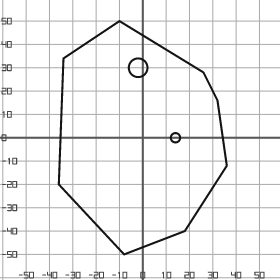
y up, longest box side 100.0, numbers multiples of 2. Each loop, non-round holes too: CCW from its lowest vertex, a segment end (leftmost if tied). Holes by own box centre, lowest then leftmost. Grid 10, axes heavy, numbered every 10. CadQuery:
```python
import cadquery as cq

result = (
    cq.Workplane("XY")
    .moveTo(-8.0, -50.0)
    .lineTo(18.0, -40.0)
    .lineTo(36.0, -12.0)
    .lineTo(32.0, 16.0)
    .lineTo(26.0, 28.0)
    .lineTo(-10.0, 50.0)
    .lineTo(-34.0, 34.0)
    .lineTo(-36.0, -20.0)
    .close()
    .moveTo(14.0, 0.0)
    .circle(2.0)
    .moveTo(-2.0, 30.0)
    .circle(4.0)
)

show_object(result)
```